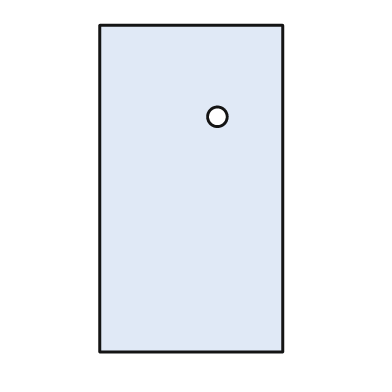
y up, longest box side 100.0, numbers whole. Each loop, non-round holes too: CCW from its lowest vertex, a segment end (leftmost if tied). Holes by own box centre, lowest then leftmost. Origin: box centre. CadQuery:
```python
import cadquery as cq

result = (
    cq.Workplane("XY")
    .moveTo(-28.0, -50.0)
    .lineTo(28.0, -50.0)
    .lineTo(28.0, 50.0)
    .lineTo(-28.0, 50.0)
    .close()
    .moveTo(8.0, 22.0)
    .circle(3.0)
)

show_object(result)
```